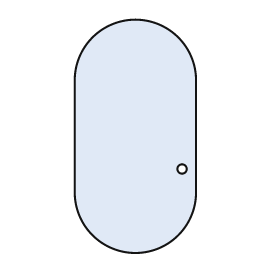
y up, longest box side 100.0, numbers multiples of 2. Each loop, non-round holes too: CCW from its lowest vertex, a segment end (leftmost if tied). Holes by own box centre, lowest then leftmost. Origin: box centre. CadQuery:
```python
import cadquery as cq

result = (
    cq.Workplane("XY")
    .moveTo(-26.0, -24.0)
    .threePointArc((0.0, -50.0), (26.0, -24.0))
    .lineTo(26.0, 24.0)
    .threePointArc((0.0, 50.0), (-26.0, 24.0))
    .close()
    .moveTo(20.0, -14.0)
    .circle(2.0)
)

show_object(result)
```